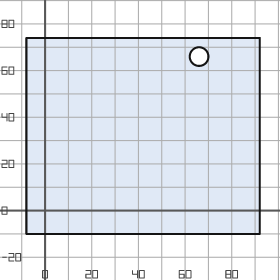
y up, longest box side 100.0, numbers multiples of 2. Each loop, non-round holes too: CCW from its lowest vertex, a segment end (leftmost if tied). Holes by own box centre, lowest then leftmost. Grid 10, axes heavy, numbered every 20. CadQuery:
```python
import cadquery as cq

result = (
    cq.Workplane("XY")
    .moveTo(-8.0, -10.0)
    .lineTo(92.0, -10.0)
    .lineTo(92.0, 74.0)
    .lineTo(-8.0, 74.0)
    .close()
    .moveTo(66.0, 66.0)
    .circle(4.0)
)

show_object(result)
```